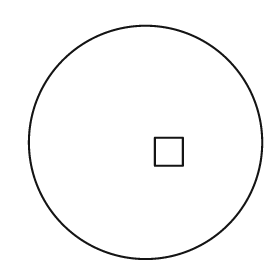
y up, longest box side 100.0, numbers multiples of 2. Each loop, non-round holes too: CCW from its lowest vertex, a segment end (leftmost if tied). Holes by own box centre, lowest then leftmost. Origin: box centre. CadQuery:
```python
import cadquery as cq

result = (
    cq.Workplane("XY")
    .moveTo(0.0, 0.0)
    .circle(50.0)
    .moveTo(4.0, -10.0)
    .lineTo(16.0, -10.0)
    .lineTo(16.0, 2.0)
    .lineTo(4.0, 2.0)
    .close()
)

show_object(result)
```